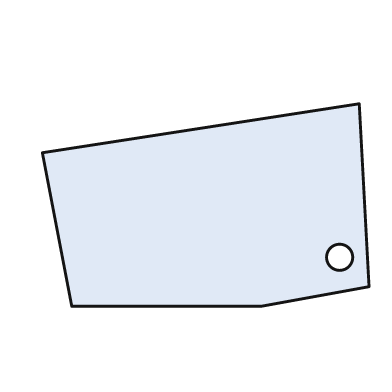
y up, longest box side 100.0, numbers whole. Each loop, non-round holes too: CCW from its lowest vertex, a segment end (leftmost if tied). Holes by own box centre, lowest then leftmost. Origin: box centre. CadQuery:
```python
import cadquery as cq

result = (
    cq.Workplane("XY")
    .moveTo(-41.0, -31.0)
    .lineTo(17.0, -31.0)
    .lineTo(50.0, -25.0)
    .lineTo(47.0, 31.0)
    .lineTo(-50.0, 16.0)
    .close()
    .moveTo(41.0, -16.0)
    .circle(4.0)
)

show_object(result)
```